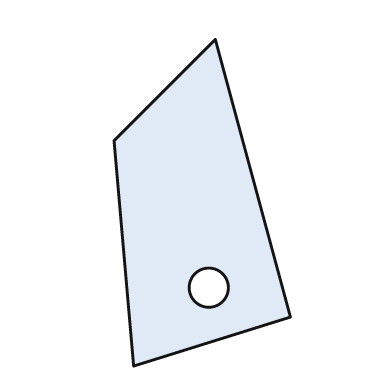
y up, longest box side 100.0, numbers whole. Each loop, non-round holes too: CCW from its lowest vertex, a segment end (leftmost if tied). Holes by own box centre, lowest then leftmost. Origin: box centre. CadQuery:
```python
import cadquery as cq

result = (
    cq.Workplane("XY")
    .moveTo(-21.0, -50.0)
    .lineTo(27.0, -35.0)
    .lineTo(4.0, 50.0)
    .lineTo(-27.0, 19.0)
    .close()
    .moveTo(2.0, -26.0)
    .circle(6.0)
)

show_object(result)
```